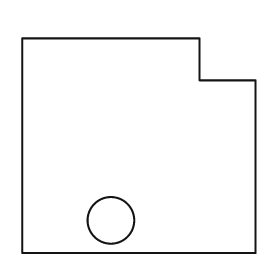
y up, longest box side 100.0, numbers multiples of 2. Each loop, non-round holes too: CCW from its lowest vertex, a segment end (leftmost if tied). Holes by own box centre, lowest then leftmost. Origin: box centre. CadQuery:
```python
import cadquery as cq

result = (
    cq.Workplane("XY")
    .moveTo(-50.0, -46.0)
    .lineTo(50.0, -46.0)
    .lineTo(50.0, 28.0)
    .lineTo(26.0, 28.0)
    .lineTo(26.0, 46.0)
    .lineTo(-50.0, 46.0)
    .close()
    .moveTo(-12.0, -32.0)
    .circle(10.0)
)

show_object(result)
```